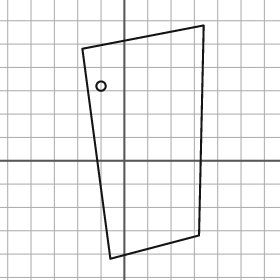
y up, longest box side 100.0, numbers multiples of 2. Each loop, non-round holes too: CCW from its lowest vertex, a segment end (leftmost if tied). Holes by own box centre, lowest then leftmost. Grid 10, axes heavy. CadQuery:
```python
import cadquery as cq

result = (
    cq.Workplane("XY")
    .moveTo(-6.0, -42.0)
    .lineTo(32.0, -32.0)
    .lineTo(34.0, 58.0)
    .lineTo(-18.0, 48.0)
    .close()
    .moveTo(-10.0, 32.0)
    .circle(2.0)
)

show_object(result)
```